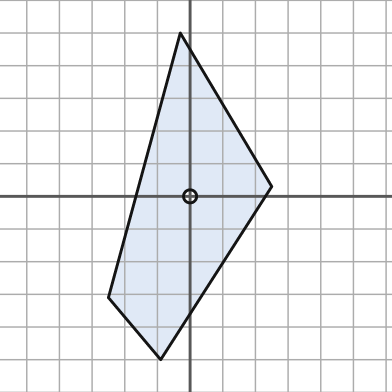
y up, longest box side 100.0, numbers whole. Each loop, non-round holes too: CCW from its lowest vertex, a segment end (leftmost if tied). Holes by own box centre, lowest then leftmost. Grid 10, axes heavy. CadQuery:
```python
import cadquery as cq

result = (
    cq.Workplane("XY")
    .moveTo(-9.0, -50.0)
    .lineTo(25.0, 3.0)
    .lineTo(-3.0, 50.0)
    .lineTo(-25.0, -31.0)
    .close()
    .moveTo(0.0, 0.0)
    .circle(2.0)
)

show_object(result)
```